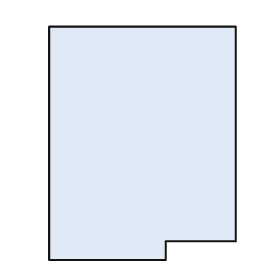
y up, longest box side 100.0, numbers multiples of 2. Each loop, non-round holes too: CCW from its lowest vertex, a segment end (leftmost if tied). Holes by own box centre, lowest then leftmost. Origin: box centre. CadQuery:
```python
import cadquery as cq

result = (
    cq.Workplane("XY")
    .moveTo(-40.0, -50.0)
    .lineTo(10.0, -50.0)
    .lineTo(10.0, -42.0)
    .lineTo(40.0, -42.0)
    .lineTo(40.0, 50.0)
    .lineTo(-40.0, 50.0)
    .close()
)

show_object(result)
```